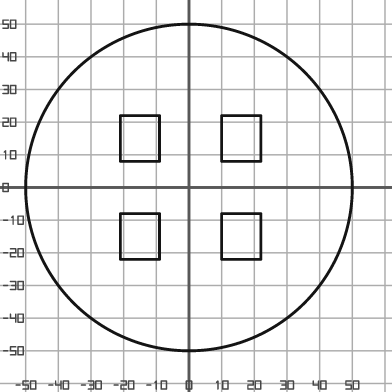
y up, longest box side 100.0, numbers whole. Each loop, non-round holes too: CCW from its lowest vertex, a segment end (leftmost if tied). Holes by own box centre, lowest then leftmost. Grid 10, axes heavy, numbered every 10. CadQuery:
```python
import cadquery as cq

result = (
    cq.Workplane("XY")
    .moveTo(0.0, 0.0)
    .circle(50.0)
    .moveTo(-21.0, -22.0)
    .lineTo(-9.0, -22.0)
    .lineTo(-9.0, -8.0)
    .lineTo(-21.0, -8.0)
    .close()
    .moveTo(10.0, -22.0)
    .lineTo(22.0, -22.0)
    .lineTo(22.0, -8.0)
    .lineTo(10.0, -8.0)
    .close()
    .moveTo(-21.0, 8.0)
    .lineTo(-9.0, 8.0)
    .lineTo(-9.0, 22.0)
    .lineTo(-21.0, 22.0)
    .close()
    .moveTo(10.0, 8.0)
    .lineTo(22.0, 8.0)
    .lineTo(22.0, 22.0)
    .lineTo(10.0, 22.0)
    .close()
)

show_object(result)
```